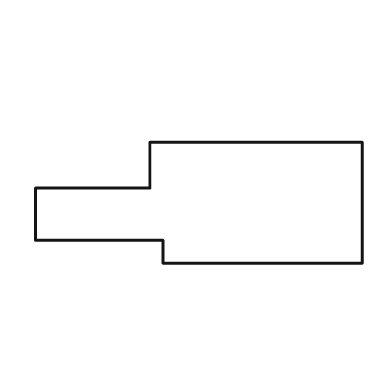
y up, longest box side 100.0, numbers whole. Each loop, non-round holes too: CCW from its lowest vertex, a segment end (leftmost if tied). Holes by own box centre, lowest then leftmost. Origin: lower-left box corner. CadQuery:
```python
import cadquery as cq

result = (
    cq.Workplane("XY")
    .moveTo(39.0, 0.0)
    .lineTo(100.0, 0.0)
    .lineTo(100.0, 37.0)
    .lineTo(35.0, 37.0)
    .lineTo(35.0, 23.0)
    .lineTo(0.0, 23.0)
    .lineTo(0.0, 7.0)
    .lineTo(39.0, 7.0)
    .close()
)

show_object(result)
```